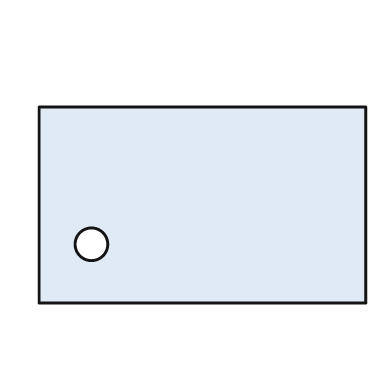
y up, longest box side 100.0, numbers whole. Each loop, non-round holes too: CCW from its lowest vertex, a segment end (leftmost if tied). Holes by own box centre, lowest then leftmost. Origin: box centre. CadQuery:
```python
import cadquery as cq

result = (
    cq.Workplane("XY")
    .moveTo(-50.0, -30.0)
    .lineTo(50.0, -30.0)
    .lineTo(50.0, 30.0)
    .lineTo(-50.0, 30.0)
    .close()
    .moveTo(-34.0, -12.0)
    .circle(5.0)
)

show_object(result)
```